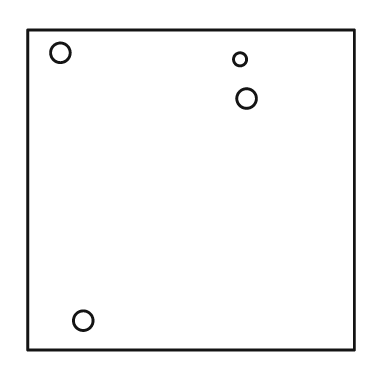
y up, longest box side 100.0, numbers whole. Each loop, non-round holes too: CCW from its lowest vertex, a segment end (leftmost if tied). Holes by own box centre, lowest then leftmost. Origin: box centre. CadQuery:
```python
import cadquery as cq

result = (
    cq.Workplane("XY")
    .moveTo(-50.0, -49.0)
    .lineTo(50.0, -49.0)
    .lineTo(50.0, 49.0)
    .lineTo(-50.0, 49.0)
    .close()
    .moveTo(-33.0, -40.0)
    .circle(3.0)
    .moveTo(17.0, 28.0)
    .circle(3.0)
    .moveTo(15.0, 40.0)
    .circle(2.0)
    .moveTo(-40.0, 42.0)
    .circle(3.0)
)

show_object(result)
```